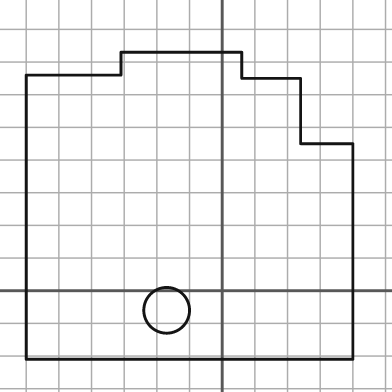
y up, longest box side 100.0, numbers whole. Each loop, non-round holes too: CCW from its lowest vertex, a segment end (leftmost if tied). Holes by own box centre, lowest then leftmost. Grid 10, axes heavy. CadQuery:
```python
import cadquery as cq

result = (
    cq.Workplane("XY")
    .moveTo(-60.0, -21.0)
    .lineTo(40.0, -21.0)
    .lineTo(40.0, 45.0)
    .lineTo(24.0, 45.0)
    .lineTo(24.0, 65.0)
    .lineTo(6.0, 65.0)
    .lineTo(6.0, 73.0)
    .lineTo(-31.0, 73.0)
    .lineTo(-31.0, 66.0)
    .lineTo(-60.0, 66.0)
    .close()
    .moveTo(-17.0, -6.0)
    .circle(7.0)
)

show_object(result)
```